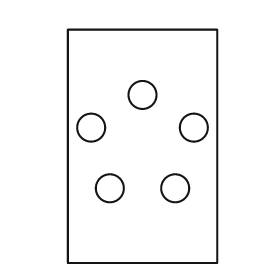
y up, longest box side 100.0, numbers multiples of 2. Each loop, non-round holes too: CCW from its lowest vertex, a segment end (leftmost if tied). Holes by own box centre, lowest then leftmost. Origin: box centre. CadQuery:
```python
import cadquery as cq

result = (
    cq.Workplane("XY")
    .moveTo(-32.0, -50.0)
    .lineTo(32.0, -50.0)
    .lineTo(32.0, 50.0)
    .lineTo(-32.0, 50.0)
    .close()
    .moveTo(-14.0, -18.0)
    .circle(6.0)
    .moveTo(14.0, -18.0)
    .circle(6.0)
    .moveTo(-22.0, 8.0)
    .circle(6.0)
    .moveTo(22.0, 8.0)
    .circle(6.0)
    .moveTo(0.0, 22.0)
    .circle(6.0)
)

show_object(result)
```